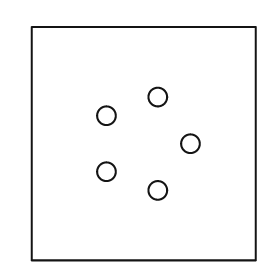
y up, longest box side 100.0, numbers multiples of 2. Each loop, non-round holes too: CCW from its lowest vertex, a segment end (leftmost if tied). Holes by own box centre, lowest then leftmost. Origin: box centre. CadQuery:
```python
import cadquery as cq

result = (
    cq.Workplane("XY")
    .moveTo(-48.0, -50.0)
    .lineTo(48.0, -50.0)
    .lineTo(48.0, 50.0)
    .lineTo(-48.0, 50.0)
    .close()
    .moveTo(6.0, -20.0)
    .circle(4.0)
    .moveTo(-16.0, -12.0)
    .circle(4.0)
    .moveTo(20.0, 0.0)
    .circle(4.0)
    .moveTo(-16.0, 12.0)
    .circle(4.0)
    .moveTo(6.0, 20.0)
    .circle(4.0)
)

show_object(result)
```